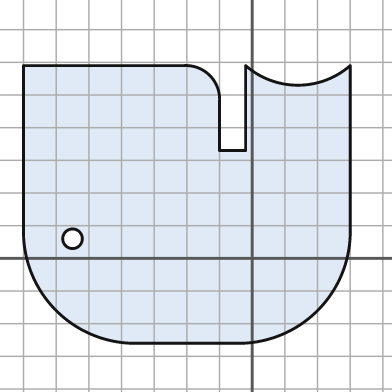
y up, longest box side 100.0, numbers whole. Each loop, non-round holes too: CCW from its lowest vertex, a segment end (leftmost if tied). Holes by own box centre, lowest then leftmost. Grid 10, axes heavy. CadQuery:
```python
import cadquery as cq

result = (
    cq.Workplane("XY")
    .moveTo(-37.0, -26.0)
    .lineTo(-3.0, -26.0)
    .threePointArc((20.0, -16.0), (30.0, 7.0))
    .lineTo(30.0, 59.0)
    .threePointArc((14.0, 53.0), (-2.0, 59.0))
    .lineTo(-2.0, 33.0)
    .lineTo(-10.0, 33.0)
    .lineTo(-10.0, 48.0)
    .threePointArc((-13.0, 56.0), (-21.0, 59.0))
    .lineTo(-70.0, 59.0)
    .lineTo(-70.0, 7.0)
    .threePointArc((-60.0, -16.0), (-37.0, -26.0))
    .close()
    .moveTo(-55.0, 6.0)
    .circle(3.0)
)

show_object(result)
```